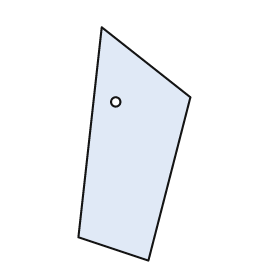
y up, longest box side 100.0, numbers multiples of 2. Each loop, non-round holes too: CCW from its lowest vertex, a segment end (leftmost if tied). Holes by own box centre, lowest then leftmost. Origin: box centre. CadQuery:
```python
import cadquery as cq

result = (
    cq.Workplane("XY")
    .moveTo(6.0, -50.0)
    .lineTo(24.0, 20.0)
    .lineTo(-14.0, 50.0)
    .lineTo(-24.0, -40.0)
    .close()
    .moveTo(-8.0, 18.0)
    .circle(2.0)
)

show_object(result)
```